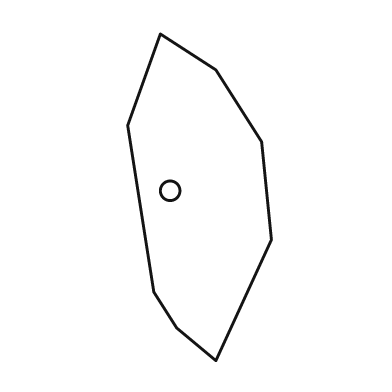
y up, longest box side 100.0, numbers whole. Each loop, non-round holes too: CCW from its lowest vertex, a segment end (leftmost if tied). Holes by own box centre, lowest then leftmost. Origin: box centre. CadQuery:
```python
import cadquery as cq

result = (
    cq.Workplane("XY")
    .moveTo(5.0, -50.0)
    .lineTo(22.0, -13.0)
    .lineTo(19.0, 17.0)
    .lineTo(5.0, 39.0)
    .lineTo(-12.0, 50.0)
    .lineTo(-22.0, 22.0)
    .lineTo(-14.0, -29.0)
    .lineTo(-7.0, -40.0)
    .close()
    .moveTo(-9.0, 2.0)
    .circle(3.0)
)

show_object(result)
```